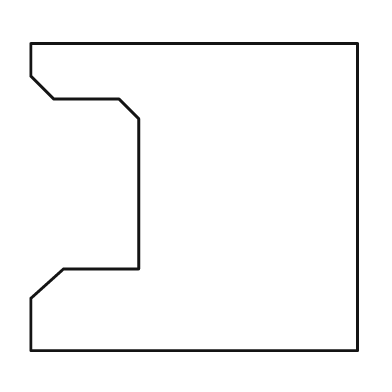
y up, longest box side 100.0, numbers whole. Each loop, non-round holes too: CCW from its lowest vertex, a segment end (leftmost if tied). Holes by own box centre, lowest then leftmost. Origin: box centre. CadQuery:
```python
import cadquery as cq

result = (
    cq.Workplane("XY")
    .moveTo(-50.0, -47.0)
    .lineTo(50.0, -47.0)
    .lineTo(50.0, 47.0)
    .lineTo(-50.0, 47.0)
    .lineTo(-50.0, 37.0)
    .lineTo(-43.0, 30.0)
    .lineTo(-23.0, 30.0)
    .lineTo(-17.0, 24.0)
    .lineTo(-17.0, -22.0)
    .lineTo(-40.0, -22.0)
    .lineTo(-50.0, -31.0)
    .close()
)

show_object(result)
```